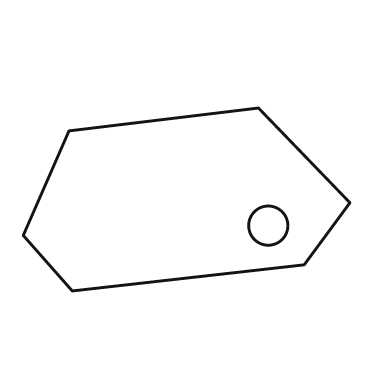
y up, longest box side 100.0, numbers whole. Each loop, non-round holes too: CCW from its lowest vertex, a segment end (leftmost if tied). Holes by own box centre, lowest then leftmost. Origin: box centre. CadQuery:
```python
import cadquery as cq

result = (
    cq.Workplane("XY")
    .moveTo(-35.0, -28.0)
    .lineTo(36.0, -20.0)
    .lineTo(50.0, -1.0)
    .lineTo(22.0, 28.0)
    .lineTo(-36.0, 21.0)
    .lineTo(-50.0, -11.0)
    .close()
    .moveTo(25.0, -8.0)
    .circle(6.0)
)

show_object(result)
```